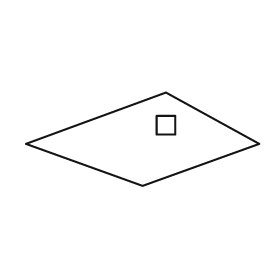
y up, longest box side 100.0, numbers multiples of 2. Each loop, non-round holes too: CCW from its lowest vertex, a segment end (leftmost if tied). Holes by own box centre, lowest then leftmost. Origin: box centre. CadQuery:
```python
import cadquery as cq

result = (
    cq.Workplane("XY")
    .moveTo(0.0, -20.0)
    .lineTo(50.0, -2.0)
    .lineTo(10.0, 20.0)
    .lineTo(-50.0, -2.0)
    .close()
    .moveTo(6.0, 2.0)
    .lineTo(14.0, 2.0)
    .lineTo(14.0, 10.0)
    .lineTo(6.0, 10.0)
    .close()
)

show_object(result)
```